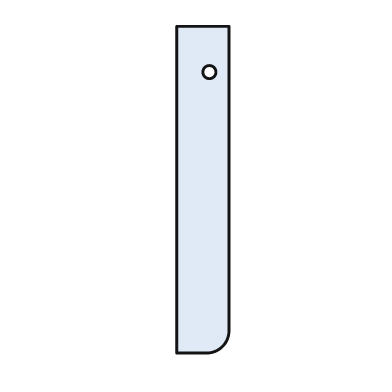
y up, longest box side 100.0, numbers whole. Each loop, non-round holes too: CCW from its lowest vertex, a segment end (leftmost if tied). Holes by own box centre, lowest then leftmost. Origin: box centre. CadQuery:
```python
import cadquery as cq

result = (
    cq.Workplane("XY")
    .moveTo(-8.0, -50.0)
    .lineTo(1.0, -50.0)
    .threePointArc((6.0, -48.0), (8.0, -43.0))
    .lineTo(8.0, 50.0)
    .lineTo(-8.0, 50.0)
    .close()
    .moveTo(2.0, 36.0)
    .circle(2.0)
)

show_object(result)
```